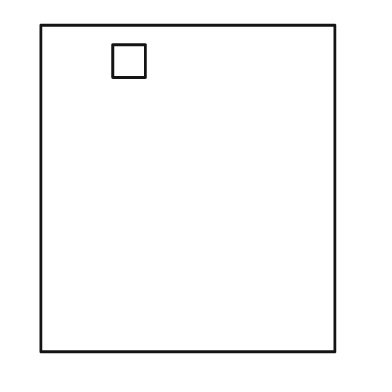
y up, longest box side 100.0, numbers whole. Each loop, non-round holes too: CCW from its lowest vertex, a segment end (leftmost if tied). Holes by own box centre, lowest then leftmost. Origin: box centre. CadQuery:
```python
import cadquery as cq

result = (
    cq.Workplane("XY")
    .moveTo(-45.0, -50.0)
    .lineTo(45.0, -50.0)
    .lineTo(45.0, 50.0)
    .lineTo(-45.0, 50.0)
    .close()
    .moveTo(-23.0, 34.0)
    .lineTo(-13.0, 34.0)
    .lineTo(-13.0, 44.0)
    .lineTo(-23.0, 44.0)
    .close()
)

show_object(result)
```